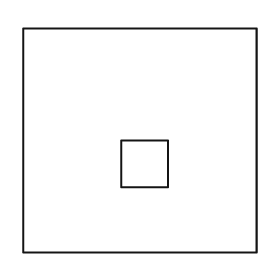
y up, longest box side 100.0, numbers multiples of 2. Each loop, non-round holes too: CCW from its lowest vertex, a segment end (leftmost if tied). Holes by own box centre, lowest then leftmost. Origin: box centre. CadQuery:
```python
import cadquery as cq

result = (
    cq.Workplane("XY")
    .moveTo(-50.0, -48.0)
    .lineTo(50.0, -48.0)
    .lineTo(50.0, 48.0)
    .lineTo(-50.0, 48.0)
    .close()
    .moveTo(-8.0, -20.0)
    .lineTo(12.0, -20.0)
    .lineTo(12.0, 0.0)
    .lineTo(-8.0, 0.0)
    .close()
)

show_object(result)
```